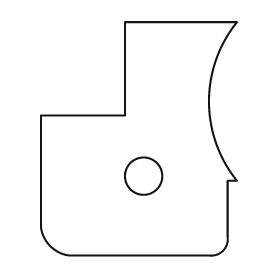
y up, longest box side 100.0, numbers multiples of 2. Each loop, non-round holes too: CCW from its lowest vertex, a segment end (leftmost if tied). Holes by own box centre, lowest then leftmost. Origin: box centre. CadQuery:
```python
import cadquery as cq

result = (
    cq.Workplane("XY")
    .moveTo(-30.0, -50.0)
    .lineTo(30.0, -50.0)
    .threePointArc((36.0, -48.0), (38.0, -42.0))
    .lineTo(38.0, -18.0)
    .lineTo(42.0, -18.0)
    .threePointArc((30.0, 16.0), (42.0, 50.0))
    .lineTo(-6.0, 50.0)
    .lineTo(-6.0, 10.0)
    .lineTo(-42.0, 10.0)
    .lineTo(-42.0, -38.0)
    .threePointArc((-38.0, -46.0), (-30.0, -50.0))
    .close()
    .moveTo(2.0, -16.0)
    .circle(8.0)
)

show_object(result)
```